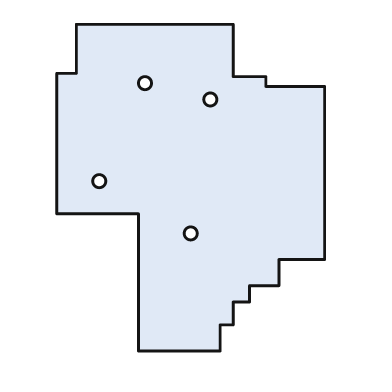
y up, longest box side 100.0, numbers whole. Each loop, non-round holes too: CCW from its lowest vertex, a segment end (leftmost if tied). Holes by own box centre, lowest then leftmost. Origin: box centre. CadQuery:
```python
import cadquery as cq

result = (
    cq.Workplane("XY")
    .moveTo(-16.0, -50.0)
    .lineTo(9.0, -50.0)
    .lineTo(9.0, -42.0)
    .lineTo(13.0, -42.0)
    .lineTo(13.0, -35.0)
    .lineTo(18.0, -35.0)
    .lineTo(18.0, -30.0)
    .lineTo(27.0, -30.0)
    .lineTo(27.0, -22.0)
    .lineTo(41.0, -22.0)
    .lineTo(41.0, 31.0)
    .lineTo(23.0, 31.0)
    .lineTo(23.0, 34.0)
    .lineTo(13.0, 34.0)
    .lineTo(13.0, 50.0)
    .lineTo(-35.0, 50.0)
    .lineTo(-35.0, 35.0)
    .lineTo(-41.0, 35.0)
    .lineTo(-41.0, -8.0)
    .lineTo(-16.0, -8.0)
    .close()
    .moveTo(0.0, -14.0)
    .circle(2.0)
    .moveTo(-28.0, 2.0)
    .circle(2.0)
    .moveTo(6.0, 27.0)
    .circle(2.0)
    .moveTo(-14.0, 32.0)
    .circle(2.0)
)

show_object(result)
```